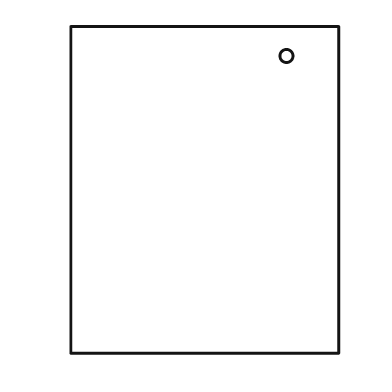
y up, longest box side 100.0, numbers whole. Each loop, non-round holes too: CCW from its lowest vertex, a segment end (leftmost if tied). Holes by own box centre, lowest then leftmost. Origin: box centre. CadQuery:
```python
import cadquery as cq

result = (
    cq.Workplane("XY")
    .moveTo(-41.0, -50.0)
    .lineTo(41.0, -50.0)
    .lineTo(41.0, 50.0)
    .lineTo(-41.0, 50.0)
    .close()
    .moveTo(25.0, 41.0)
    .circle(2.0)
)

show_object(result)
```